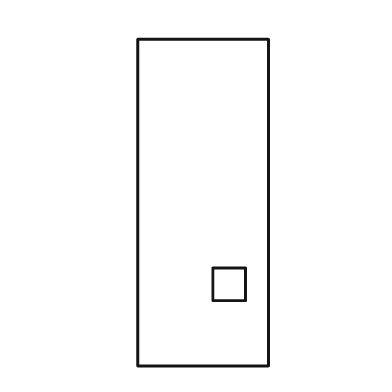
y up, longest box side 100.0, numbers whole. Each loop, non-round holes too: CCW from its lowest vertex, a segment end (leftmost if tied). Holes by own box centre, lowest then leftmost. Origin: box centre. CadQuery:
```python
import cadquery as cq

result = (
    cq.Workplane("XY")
    .moveTo(-20.0, -50.0)
    .lineTo(20.0, -50.0)
    .lineTo(20.0, 50.0)
    .lineTo(-20.0, 50.0)
    .close()
    .moveTo(3.0, -30.0)
    .lineTo(13.0, -30.0)
    .lineTo(13.0, -20.0)
    .lineTo(3.0, -20.0)
    .close()
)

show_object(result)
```